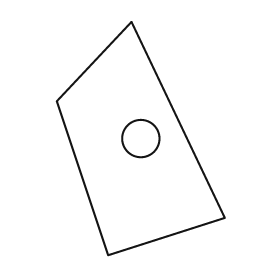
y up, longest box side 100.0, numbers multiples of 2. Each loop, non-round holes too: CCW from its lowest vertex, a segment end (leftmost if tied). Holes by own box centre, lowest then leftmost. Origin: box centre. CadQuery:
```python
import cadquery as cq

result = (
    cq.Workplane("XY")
    .moveTo(-14.0, -50.0)
    .lineTo(36.0, -34.0)
    .lineTo(-4.0, 50.0)
    .lineTo(-36.0, 16.0)
    .close()
    .moveTo(0.0, 0.0)
    .circle(8.0)
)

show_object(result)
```